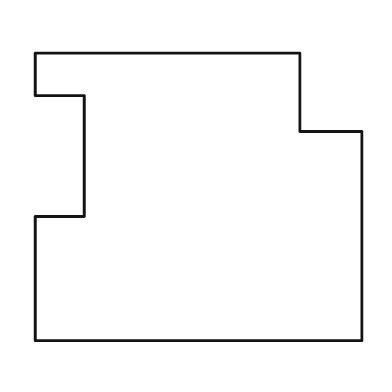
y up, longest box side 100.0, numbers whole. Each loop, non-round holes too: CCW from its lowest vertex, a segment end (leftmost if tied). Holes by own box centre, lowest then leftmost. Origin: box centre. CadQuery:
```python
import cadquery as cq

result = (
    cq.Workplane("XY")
    .moveTo(-50.0, -44.0)
    .lineTo(50.0, -44.0)
    .lineTo(50.0, 20.0)
    .lineTo(31.0, 20.0)
    .lineTo(31.0, 44.0)
    .lineTo(-50.0, 44.0)
    .lineTo(-50.0, 31.0)
    .lineTo(-35.0, 31.0)
    .lineTo(-35.0, -6.0)
    .lineTo(-50.0, -6.0)
    .close()
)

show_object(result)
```